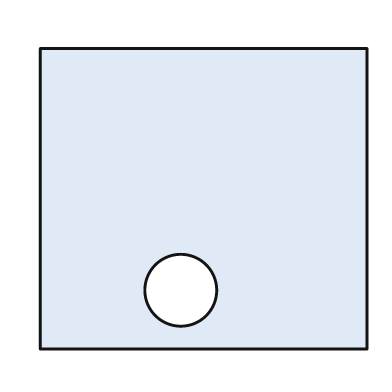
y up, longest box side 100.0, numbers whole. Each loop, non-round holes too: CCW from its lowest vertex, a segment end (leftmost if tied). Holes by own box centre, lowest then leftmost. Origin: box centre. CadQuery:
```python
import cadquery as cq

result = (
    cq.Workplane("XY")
    .moveTo(-50.0, -46.0)
    .lineTo(50.0, -46.0)
    .lineTo(50.0, 46.0)
    .lineTo(-50.0, 46.0)
    .close()
    .moveTo(-7.0, -28.0)
    .circle(11.0)
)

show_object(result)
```